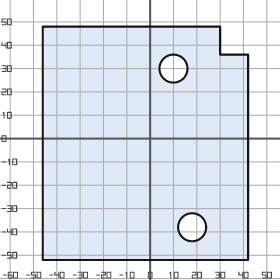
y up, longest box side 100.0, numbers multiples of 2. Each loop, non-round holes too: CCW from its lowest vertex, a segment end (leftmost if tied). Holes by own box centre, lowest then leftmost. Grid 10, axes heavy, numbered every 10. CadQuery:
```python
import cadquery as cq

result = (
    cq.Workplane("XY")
    .moveTo(-46.0, -52.0)
    .lineTo(42.0, -52.0)
    .lineTo(42.0, 36.0)
    .lineTo(30.0, 36.0)
    .lineTo(30.0, 48.0)
    .lineTo(-46.0, 48.0)
    .close()
    .moveTo(18.0, -38.0)
    .circle(6.0)
    .moveTo(10.0, 30.0)
    .circle(6.0)
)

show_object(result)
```